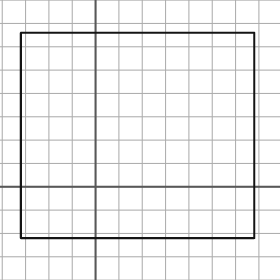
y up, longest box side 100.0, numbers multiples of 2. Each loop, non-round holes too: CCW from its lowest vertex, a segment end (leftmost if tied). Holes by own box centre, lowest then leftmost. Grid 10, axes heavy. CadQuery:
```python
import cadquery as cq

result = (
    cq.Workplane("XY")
    .moveTo(-32.0, -22.0)
    .lineTo(68.0, -22.0)
    .lineTo(68.0, 66.0)
    .lineTo(-32.0, 66.0)
    .close()
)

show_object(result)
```